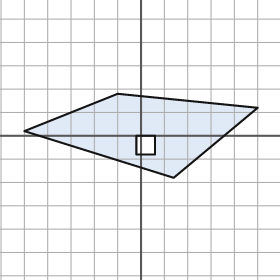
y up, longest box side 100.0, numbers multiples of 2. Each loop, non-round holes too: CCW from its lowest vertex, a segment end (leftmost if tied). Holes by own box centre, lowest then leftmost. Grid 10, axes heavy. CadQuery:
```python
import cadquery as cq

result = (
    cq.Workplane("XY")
    .moveTo(14.0, -18.0)
    .lineTo(50.0, 12.0)
    .lineTo(-10.0, 18.0)
    .lineTo(-50.0, 2.0)
    .close()
    .moveTo(-2.0, -8.0)
    .lineTo(6.0, -8.0)
    .lineTo(6.0, 0.0)
    .lineTo(-2.0, 0.0)
    .close()
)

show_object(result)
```